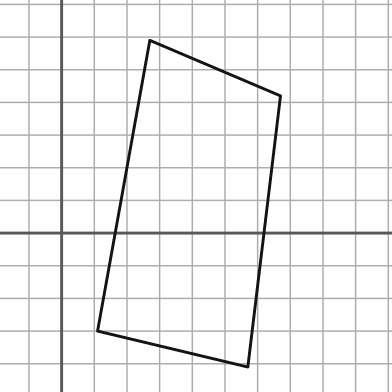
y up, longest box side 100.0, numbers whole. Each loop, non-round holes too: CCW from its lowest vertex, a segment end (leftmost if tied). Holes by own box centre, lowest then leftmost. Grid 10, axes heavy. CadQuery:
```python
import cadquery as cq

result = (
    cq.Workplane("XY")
    .moveTo(57.0, -41.0)
    .lineTo(67.0, 42.0)
    .lineTo(27.0, 59.0)
    .lineTo(11.0, -30.0)
    .close()
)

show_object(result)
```